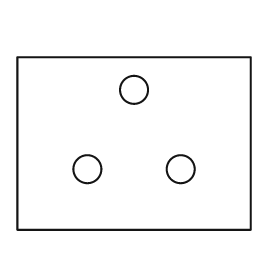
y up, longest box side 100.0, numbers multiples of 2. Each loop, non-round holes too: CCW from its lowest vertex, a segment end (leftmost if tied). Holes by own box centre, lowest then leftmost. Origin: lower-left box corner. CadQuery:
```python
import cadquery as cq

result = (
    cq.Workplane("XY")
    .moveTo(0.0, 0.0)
    .lineTo(100.0, 0.0)
    .lineTo(100.0, 74.0)
    .lineTo(0.0, 74.0)
    .close()
    .moveTo(30.0, 26.0)
    .circle(6.0)
    .moveTo(70.0, 26.0)
    .circle(6.0)
    .moveTo(50.0, 60.0)
    .circle(6.0)
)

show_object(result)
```